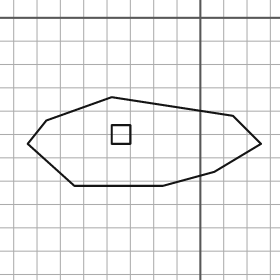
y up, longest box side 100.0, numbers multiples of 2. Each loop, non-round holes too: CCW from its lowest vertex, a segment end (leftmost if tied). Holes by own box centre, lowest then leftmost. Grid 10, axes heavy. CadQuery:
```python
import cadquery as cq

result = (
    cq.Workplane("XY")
    .moveTo(-54.0, -72.0)
    .lineTo(-16.0, -72.0)
    .lineTo(6.0, -66.0)
    .lineTo(26.0, -54.0)
    .lineTo(14.0, -42.0)
    .lineTo(-38.0, -34.0)
    .lineTo(-66.0, -44.0)
    .lineTo(-74.0, -54.0)
    .close()
    .moveTo(-38.0, -54.0)
    .lineTo(-30.0, -54.0)
    .lineTo(-30.0, -46.0)
    .lineTo(-38.0, -46.0)
    .close()
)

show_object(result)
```